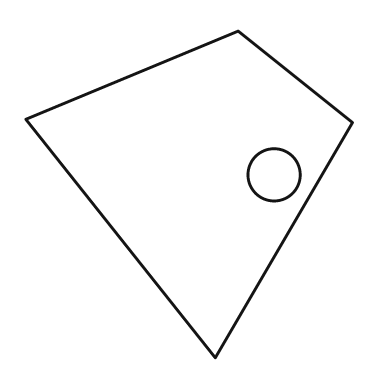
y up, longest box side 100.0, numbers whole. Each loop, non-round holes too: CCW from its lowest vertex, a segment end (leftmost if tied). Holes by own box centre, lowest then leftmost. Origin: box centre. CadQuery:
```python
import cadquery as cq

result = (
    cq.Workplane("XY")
    .moveTo(8.0, -50.0)
    .lineTo(50.0, 22.0)
    .lineTo(15.0, 50.0)
    .lineTo(-50.0, 23.0)
    .close()
    .moveTo(26.0, 6.0)
    .circle(8.0)
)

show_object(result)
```